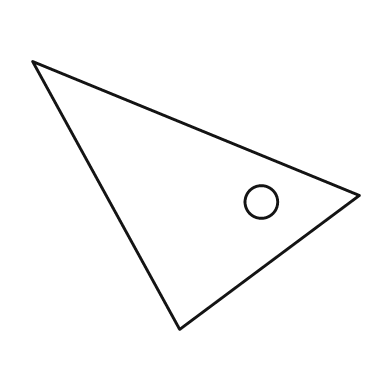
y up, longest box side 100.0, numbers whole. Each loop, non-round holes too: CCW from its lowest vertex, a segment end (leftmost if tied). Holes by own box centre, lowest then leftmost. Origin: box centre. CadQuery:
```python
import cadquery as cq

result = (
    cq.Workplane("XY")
    .moveTo(-5.0, -41.0)
    .lineTo(50.0, 0.0)
    .lineTo(-50.0, 41.0)
    .close()
    .moveTo(20.0, -2.0)
    .circle(5.0)
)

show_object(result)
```